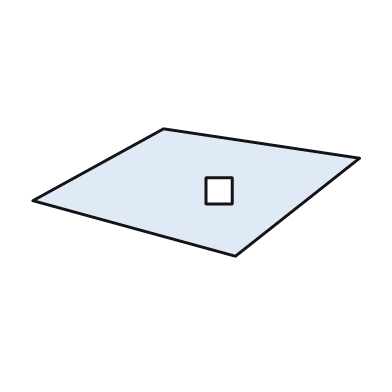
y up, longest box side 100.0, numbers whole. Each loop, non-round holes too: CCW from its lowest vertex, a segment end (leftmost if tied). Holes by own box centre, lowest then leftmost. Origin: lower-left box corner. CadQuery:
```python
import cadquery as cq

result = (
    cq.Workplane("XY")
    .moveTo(62.0, 0.0)
    .lineTo(100.0, 30.0)
    .lineTo(40.0, 39.0)
    .lineTo(0.0, 17.0)
    .close()
    .moveTo(53.0, 16.0)
    .lineTo(61.0, 16.0)
    .lineTo(61.0, 24.0)
    .lineTo(53.0, 24.0)
    .close()
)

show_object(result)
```